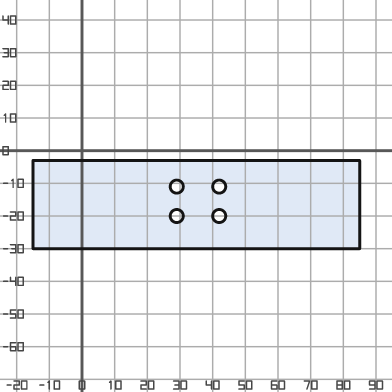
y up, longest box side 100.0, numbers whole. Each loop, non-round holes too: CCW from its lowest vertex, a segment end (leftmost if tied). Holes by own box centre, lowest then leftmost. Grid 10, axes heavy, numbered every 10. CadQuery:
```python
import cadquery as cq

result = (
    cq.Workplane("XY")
    .moveTo(-15.0, -30.0)
    .lineTo(85.0, -30.0)
    .lineTo(85.0, -3.0)
    .lineTo(-15.0, -3.0)
    .close()
    .moveTo(29.0, -20.0)
    .circle(2.0)
    .moveTo(42.0, -20.0)
    .circle(2.0)
    .moveTo(29.0, -11.0)
    .circle(2.0)
    .moveTo(42.0, -11.0)
    .circle(2.0)
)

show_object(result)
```